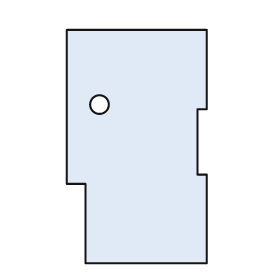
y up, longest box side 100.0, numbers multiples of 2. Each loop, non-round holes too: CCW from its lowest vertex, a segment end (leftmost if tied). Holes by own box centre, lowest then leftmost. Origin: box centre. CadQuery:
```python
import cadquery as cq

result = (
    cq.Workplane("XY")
    .moveTo(-22.0, -50.0)
    .lineTo(30.0, -50.0)
    .lineTo(30.0, -12.0)
    .lineTo(26.0, -12.0)
    .lineTo(26.0, 16.0)
    .lineTo(30.0, 16.0)
    .lineTo(30.0, 50.0)
    .lineTo(-30.0, 50.0)
    .lineTo(-30.0, -16.0)
    .lineTo(-22.0, -16.0)
    .close()
    .moveTo(-16.0, 18.0)
    .circle(4.0)
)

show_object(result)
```